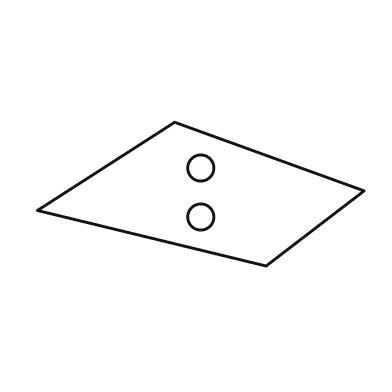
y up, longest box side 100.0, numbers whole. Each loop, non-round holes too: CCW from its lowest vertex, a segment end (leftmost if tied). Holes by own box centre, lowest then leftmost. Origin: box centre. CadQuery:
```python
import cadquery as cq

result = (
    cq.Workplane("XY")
    .moveTo(20.0, -22.0)
    .lineTo(50.0, 1.0)
    .lineTo(-8.0, 22.0)
    .lineTo(-50.0, -5.0)
    .close()
    .moveTo(0.0, -7.0)
    .circle(4.0)
    .moveTo(0.0, 8.0)
    .circle(4.0)
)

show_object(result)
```